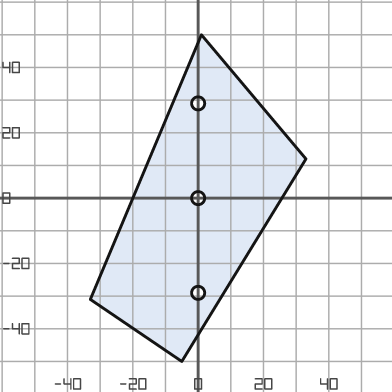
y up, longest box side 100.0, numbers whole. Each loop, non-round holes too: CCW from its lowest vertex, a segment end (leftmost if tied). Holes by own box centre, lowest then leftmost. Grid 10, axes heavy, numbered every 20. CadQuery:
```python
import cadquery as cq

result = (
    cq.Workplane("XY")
    .moveTo(-5.0, -50.0)
    .lineTo(33.0, 12.0)
    .lineTo(1.0, 50.0)
    .lineTo(-33.0, -31.0)
    .close()
    .moveTo(0.0, -29.0)
    .circle(2.0)
    .moveTo(0.0, 0.0)
    .circle(2.0)
    .moveTo(0.0, 29.0)
    .circle(2.0)
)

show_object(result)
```